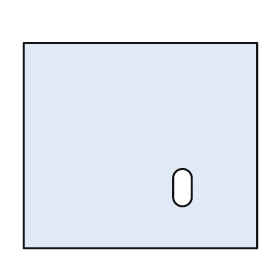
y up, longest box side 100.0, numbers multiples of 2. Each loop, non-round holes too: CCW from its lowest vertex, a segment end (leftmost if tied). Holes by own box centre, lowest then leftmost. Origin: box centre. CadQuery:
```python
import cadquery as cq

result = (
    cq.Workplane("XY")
    .moveTo(-50.0, -44.0)
    .lineTo(50.0, -44.0)
    .lineTo(50.0, 44.0)
    .lineTo(-50.0, 44.0)
    .close()
    .moveTo(14.0, -22.0)
    .threePointArc((18.0, -26.0), (22.0, -22.0))
    .lineTo(22.0, -14.0)
    .threePointArc((18.0, -10.0), (14.0, -14.0))
    .close()
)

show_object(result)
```